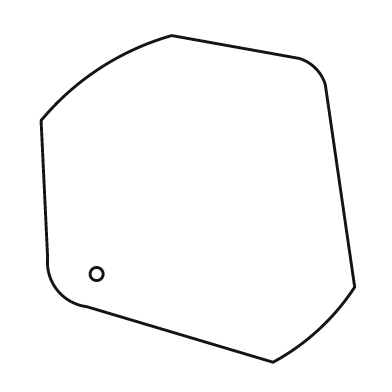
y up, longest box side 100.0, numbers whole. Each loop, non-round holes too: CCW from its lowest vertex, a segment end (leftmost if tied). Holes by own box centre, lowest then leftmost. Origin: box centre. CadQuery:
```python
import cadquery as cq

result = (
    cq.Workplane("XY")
    .moveTo(23.0, -50.0)
    .threePointArc((37.0, -40.0), (48.0, -27.0))
    .lineTo(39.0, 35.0)
    .threePointArc((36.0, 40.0), (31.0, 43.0))
    .lineTo(-8.0, 50.0)
    .threePointArc((-30.0, 40.0), (-48.0, 24.0))
    .lineTo(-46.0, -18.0)
    .threePointArc((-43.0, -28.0), (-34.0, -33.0))
    .close()
    .moveTo(-31.0, -23.0)
    .circle(2.0)
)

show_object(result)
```